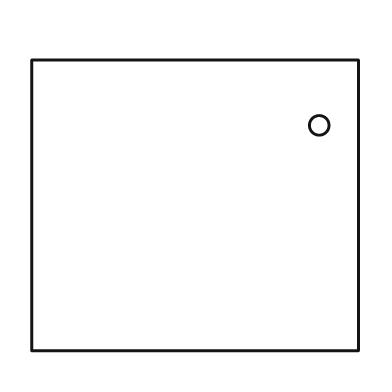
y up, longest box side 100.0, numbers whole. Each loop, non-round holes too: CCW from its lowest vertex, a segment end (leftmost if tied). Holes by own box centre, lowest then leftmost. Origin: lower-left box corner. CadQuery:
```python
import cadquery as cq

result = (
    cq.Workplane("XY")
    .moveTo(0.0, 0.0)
    .lineTo(100.0, 0.0)
    .lineTo(100.0, 89.0)
    .lineTo(0.0, 89.0)
    .close()
    .moveTo(88.0, 69.0)
    .circle(3.0)
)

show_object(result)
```